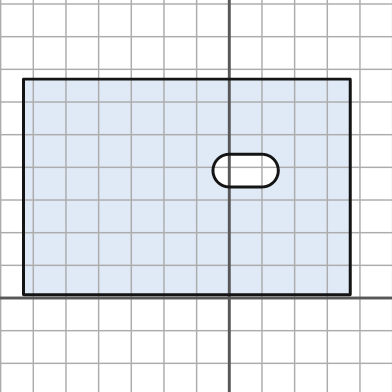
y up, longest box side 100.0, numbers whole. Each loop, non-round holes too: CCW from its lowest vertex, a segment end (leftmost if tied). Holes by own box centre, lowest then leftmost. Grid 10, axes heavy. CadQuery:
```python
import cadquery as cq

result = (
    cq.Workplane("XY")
    .moveTo(-63.0, 1.0)
    .lineTo(37.0, 1.0)
    .lineTo(37.0, 67.0)
    .lineTo(-63.0, 67.0)
    .close()
    .moveTo(0.0, 34.0)
    .lineTo(10.0, 34.0)
    .threePointArc((15.0, 39.0), (10.0, 44.0))
    .lineTo(0.0, 44.0)
    .threePointArc((-5.0, 39.0), (0.0, 34.0))
    .close()
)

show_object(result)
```